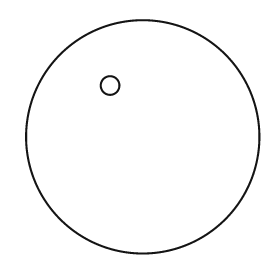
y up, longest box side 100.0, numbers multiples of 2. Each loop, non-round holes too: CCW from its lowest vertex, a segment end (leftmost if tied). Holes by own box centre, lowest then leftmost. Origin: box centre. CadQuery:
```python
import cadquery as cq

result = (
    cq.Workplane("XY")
    .moveTo(0.0, 0.0)
    .circle(50.0)
    .moveTo(-14.0, 22.0)
    .circle(4.0)
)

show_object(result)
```